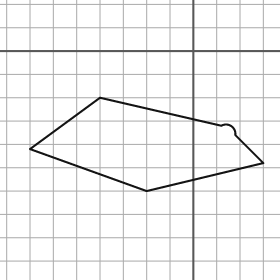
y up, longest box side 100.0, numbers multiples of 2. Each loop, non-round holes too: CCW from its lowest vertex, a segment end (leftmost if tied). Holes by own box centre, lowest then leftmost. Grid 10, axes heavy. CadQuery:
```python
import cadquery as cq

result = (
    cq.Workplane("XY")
    .moveTo(-20.0, -60.0)
    .lineTo(30.0, -48.0)
    .lineTo(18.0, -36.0)
    .threePointArc((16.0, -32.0), (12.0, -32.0))
    .lineTo(-40.0, -20.0)
    .lineTo(-70.0, -42.0)
    .close()
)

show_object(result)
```